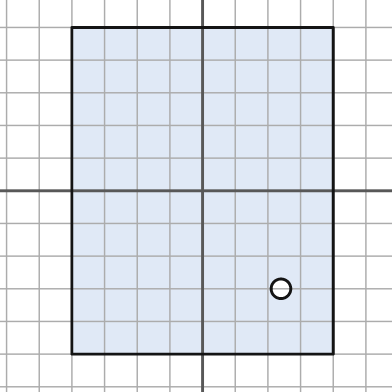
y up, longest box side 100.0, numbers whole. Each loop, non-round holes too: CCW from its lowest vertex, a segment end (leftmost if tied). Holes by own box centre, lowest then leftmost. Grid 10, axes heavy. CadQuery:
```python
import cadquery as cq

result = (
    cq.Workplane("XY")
    .moveTo(-40.0, -50.0)
    .lineTo(40.0, -50.0)
    .lineTo(40.0, 50.0)
    .lineTo(-40.0, 50.0)
    .close()
    .moveTo(24.0, -30.0)
    .circle(3.0)
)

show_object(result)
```